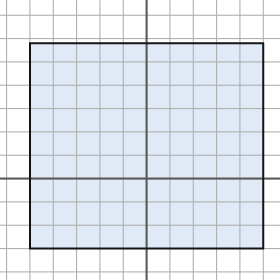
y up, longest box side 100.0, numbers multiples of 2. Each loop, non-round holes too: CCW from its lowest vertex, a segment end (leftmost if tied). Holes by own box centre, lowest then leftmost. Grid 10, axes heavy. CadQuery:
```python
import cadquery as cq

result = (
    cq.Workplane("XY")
    .moveTo(-50.0, -30.0)
    .lineTo(50.0, -30.0)
    .lineTo(50.0, 58.0)
    .lineTo(-50.0, 58.0)
    .close()
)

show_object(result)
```